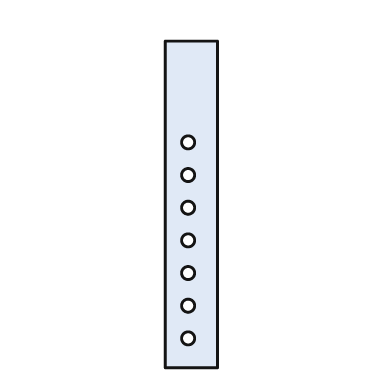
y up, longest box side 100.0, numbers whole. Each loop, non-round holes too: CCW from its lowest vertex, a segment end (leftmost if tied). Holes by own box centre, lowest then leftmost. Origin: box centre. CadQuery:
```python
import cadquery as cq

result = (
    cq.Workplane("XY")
    .moveTo(-8.0, -50.0)
    .lineTo(8.0, -50.0)
    .lineTo(8.0, 50.0)
    .lineTo(-8.0, 50.0)
    .close()
    .moveTo(-1.0, -41.0)
    .circle(2.0)
    .moveTo(-1.0, -31.0)
    .circle(2.0)
    .moveTo(-1.0, -21.0)
    .circle(2.0)
    .moveTo(-1.0, -11.0)
    .circle(2.0)
    .moveTo(-1.0, -1.0)
    .circle(2.0)
    .moveTo(-1.0, 9.0)
    .circle(2.0)
    .moveTo(-1.0, 19.0)
    .circle(2.0)
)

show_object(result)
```